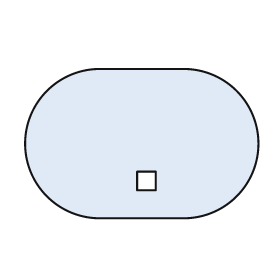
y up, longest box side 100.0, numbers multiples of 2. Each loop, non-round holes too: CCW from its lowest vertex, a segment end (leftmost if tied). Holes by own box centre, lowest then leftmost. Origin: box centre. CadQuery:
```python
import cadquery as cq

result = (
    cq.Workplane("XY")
    .moveTo(-18.0, -32.0)
    .lineTo(18.0, -32.0)
    .threePointArc((50.0, 0.0), (18.0, 32.0))
    .lineTo(-18.0, 32.0)
    .threePointArc((-50.0, 0.0), (-18.0, -32.0))
    .close()
    .moveTo(-2.0, -20.0)
    .lineTo(6.0, -20.0)
    .lineTo(6.0, -12.0)
    .lineTo(-2.0, -12.0)
    .close()
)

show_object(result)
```